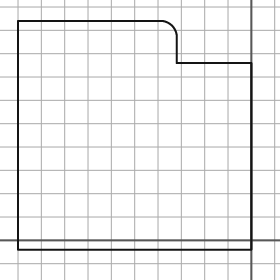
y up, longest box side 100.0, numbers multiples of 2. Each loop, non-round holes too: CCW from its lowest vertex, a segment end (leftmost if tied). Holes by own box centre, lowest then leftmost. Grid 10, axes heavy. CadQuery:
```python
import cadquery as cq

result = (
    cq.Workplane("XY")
    .moveTo(-100.0, -4.0)
    .lineTo(0.0, -4.0)
    .lineTo(0.0, 76.0)
    .lineTo(-32.0, 76.0)
    .lineTo(-32.0, 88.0)
    .threePointArc((-34.0, 92.0), (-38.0, 94.0))
    .lineTo(-100.0, 94.0)
    .close()
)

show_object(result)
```